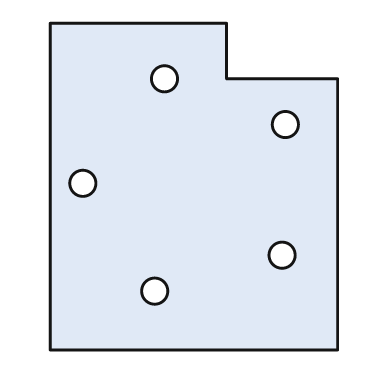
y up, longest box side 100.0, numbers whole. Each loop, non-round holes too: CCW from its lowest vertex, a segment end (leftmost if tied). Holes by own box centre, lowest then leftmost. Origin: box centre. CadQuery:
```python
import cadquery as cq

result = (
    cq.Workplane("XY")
    .moveTo(-44.0, -50.0)
    .lineTo(44.0, -50.0)
    .lineTo(44.0, 33.0)
    .lineTo(10.0, 33.0)
    .lineTo(10.0, 50.0)
    .lineTo(-44.0, 50.0)
    .close()
    .moveTo(-12.0, -32.0)
    .circle(4.0)
    .moveTo(27.0, -21.0)
    .circle(4.0)
    .moveTo(-34.0, 1.0)
    .circle(4.0)
    .moveTo(28.0, 19.0)
    .circle(4.0)
    .moveTo(-9.0, 33.0)
    .circle(4.0)
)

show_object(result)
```